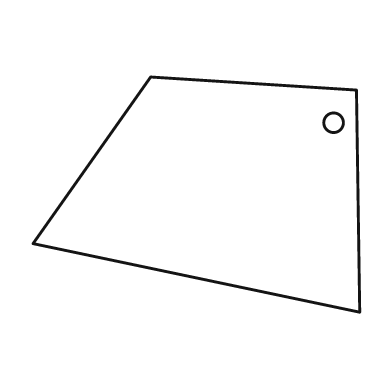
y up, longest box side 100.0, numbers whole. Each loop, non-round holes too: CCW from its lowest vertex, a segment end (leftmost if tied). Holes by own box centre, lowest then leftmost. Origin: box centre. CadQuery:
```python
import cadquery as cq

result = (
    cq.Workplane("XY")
    .moveTo(50.0, -36.0)
    .lineTo(49.0, 32.0)
    .lineTo(-14.0, 36.0)
    .lineTo(-50.0, -15.0)
    .close()
    .moveTo(42.0, 22.0)
    .circle(3.0)
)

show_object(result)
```